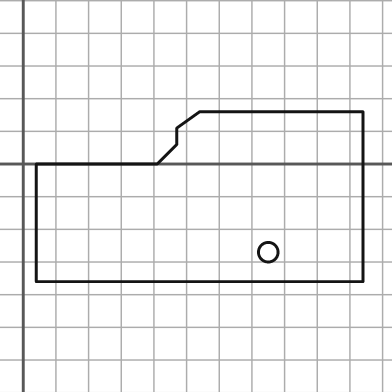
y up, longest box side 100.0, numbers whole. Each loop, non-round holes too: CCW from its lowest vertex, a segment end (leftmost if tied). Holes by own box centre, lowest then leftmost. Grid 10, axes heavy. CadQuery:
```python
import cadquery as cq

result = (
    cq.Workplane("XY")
    .moveTo(4.0, -36.0)
    .lineTo(104.0, -36.0)
    .lineTo(104.0, 16.0)
    .lineTo(54.0, 16.0)
    .lineTo(47.0, 11.0)
    .lineTo(47.0, 6.0)
    .lineTo(41.0, 0.0)
    .lineTo(4.0, 0.0)
    .close()
    .moveTo(75.0, -27.0)
    .circle(3.0)
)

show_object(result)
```